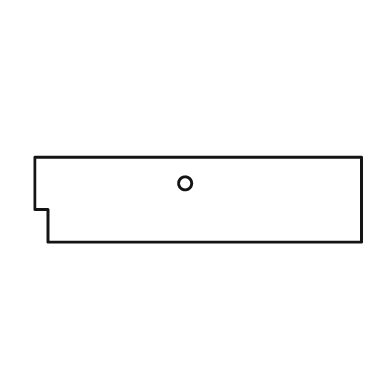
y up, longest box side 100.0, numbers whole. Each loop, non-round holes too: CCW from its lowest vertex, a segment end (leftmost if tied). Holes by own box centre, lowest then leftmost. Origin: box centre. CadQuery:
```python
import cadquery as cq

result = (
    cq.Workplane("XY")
    .moveTo(-46.0, -13.0)
    .lineTo(50.0, -13.0)
    .lineTo(50.0, 13.0)
    .lineTo(-50.0, 13.0)
    .lineTo(-50.0, -3.0)
    .lineTo(-46.0, -3.0)
    .close()
    .moveTo(-4.0, 5.0)
    .circle(2.0)
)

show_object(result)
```